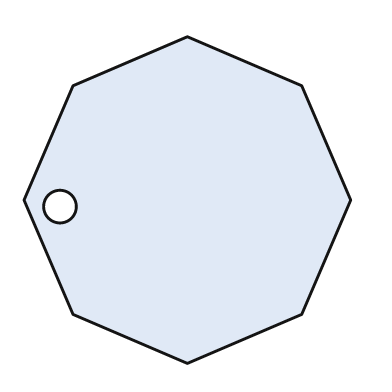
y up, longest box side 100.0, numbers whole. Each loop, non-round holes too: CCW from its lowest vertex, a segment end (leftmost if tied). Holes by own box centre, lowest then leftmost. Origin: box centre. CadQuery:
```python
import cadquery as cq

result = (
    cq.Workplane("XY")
    .moveTo(0.0, -50.0)
    .lineTo(35.0, -35.0)
    .lineTo(50.0, 0.0)
    .lineTo(35.0, 35.0)
    .lineTo(0.0, 50.0)
    .lineTo(-35.0, 35.0)
    .lineTo(-50.0, 0.0)
    .lineTo(-35.0, -35.0)
    .close()
    .moveTo(-39.0, -2.0)
    .circle(5.0)
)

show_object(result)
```